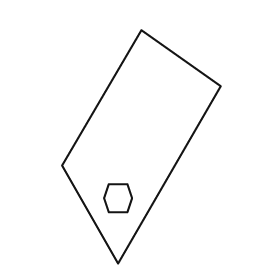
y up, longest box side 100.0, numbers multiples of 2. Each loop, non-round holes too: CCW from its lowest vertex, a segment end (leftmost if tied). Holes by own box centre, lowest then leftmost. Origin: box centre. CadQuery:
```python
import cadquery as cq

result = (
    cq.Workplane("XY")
    .moveTo(-10.0, -50.0)
    .lineTo(34.0, 26.0)
    .lineTo(0.0, 50.0)
    .lineTo(-34.0, -8.0)
    .close()
    .moveTo(-14.0, -28.0)
    .lineTo(-6.0, -28.0)
    .lineTo(-4.0, -22.0)
    .lineTo(-6.0, -16.0)
    .lineTo(-14.0, -16.0)
    .lineTo(-16.0, -22.0)
    .close()
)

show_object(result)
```